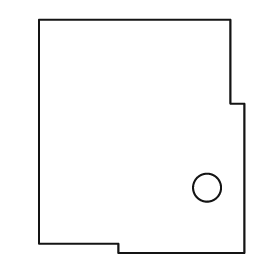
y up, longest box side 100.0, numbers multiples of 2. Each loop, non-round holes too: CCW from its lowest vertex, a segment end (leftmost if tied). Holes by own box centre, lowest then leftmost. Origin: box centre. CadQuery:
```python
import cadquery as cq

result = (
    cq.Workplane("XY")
    .moveTo(-10.0, -50.0)
    .lineTo(44.0, -50.0)
    .lineTo(44.0, 14.0)
    .lineTo(38.0, 14.0)
    .lineTo(38.0, 50.0)
    .lineTo(-44.0, 50.0)
    .lineTo(-44.0, -46.0)
    .lineTo(-10.0, -46.0)
    .close()
    .moveTo(28.0, -22.0)
    .circle(6.0)
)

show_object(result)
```